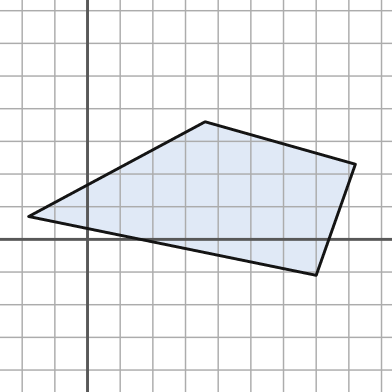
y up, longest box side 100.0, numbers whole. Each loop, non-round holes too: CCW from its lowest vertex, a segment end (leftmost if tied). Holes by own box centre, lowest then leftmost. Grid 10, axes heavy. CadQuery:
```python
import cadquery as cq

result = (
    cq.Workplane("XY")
    .moveTo(70.0, -11.0)
    .lineTo(82.0, 23.0)
    .lineTo(36.0, 36.0)
    .lineTo(-18.0, 7.0)
    .close()
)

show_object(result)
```